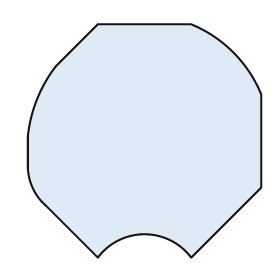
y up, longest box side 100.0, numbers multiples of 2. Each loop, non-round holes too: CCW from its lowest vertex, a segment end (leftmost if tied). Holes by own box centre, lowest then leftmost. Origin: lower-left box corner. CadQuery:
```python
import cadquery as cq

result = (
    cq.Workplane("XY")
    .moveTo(30.0, 0.0)
    .threePointArc((50.0, 10.0), (70.0, 0.0))
    .lineTo(100.0, 30.0)
    .lineTo(100.0, 70.0)
    .threePointArc((88.0, 88.0), (70.0, 100.0))
    .lineTo(30.0, 100.0)
    .lineTo(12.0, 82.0)
    .threePointArc((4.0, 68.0), (0.0, 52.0))
    .lineTo(0.0, 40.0)
    .threePointArc((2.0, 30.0), (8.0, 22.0))
    .close()
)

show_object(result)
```